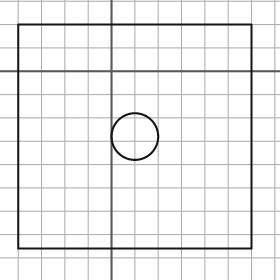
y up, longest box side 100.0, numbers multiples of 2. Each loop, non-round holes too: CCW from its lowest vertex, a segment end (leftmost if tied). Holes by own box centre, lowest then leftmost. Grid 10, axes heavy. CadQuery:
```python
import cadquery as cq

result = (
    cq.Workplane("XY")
    .moveTo(-40.0, -76.0)
    .lineTo(60.0, -76.0)
    .lineTo(60.0, 20.0)
    .lineTo(-40.0, 20.0)
    .close()
    .moveTo(10.0, -28.0)
    .circle(10.0)
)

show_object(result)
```